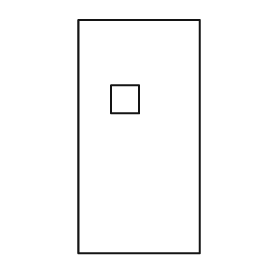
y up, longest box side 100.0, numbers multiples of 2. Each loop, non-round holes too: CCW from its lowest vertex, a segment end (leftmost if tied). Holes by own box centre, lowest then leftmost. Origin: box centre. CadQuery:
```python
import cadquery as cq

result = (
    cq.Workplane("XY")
    .moveTo(-26.0, -50.0)
    .lineTo(26.0, -50.0)
    .lineTo(26.0, 50.0)
    .lineTo(-26.0, 50.0)
    .close()
    .moveTo(-12.0, 10.0)
    .lineTo(0.0, 10.0)
    .lineTo(0.0, 22.0)
    .lineTo(-12.0, 22.0)
    .close()
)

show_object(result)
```